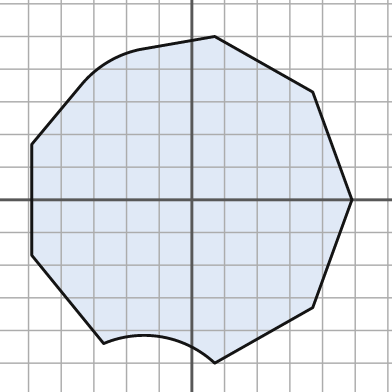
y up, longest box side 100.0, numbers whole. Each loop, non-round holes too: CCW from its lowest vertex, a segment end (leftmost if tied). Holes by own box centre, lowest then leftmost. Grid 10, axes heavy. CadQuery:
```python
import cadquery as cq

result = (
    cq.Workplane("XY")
    .moveTo(7.0, -50.0)
    .lineTo(37.0, -33.0)
    .lineTo(49.0, 0.0)
    .lineTo(37.0, 33.0)
    .lineTo(7.0, 50.0)
    .lineTo(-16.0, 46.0)
    .threePointArc((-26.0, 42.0), (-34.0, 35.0))
    .lineTo(-49.0, 17.0)
    .lineTo(-49.0, -17.0)
    .lineTo(-27.0, -44.0)
    .threePointArc((-9.0, -42.0), (7.0, -50.0))
    .close()
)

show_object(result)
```